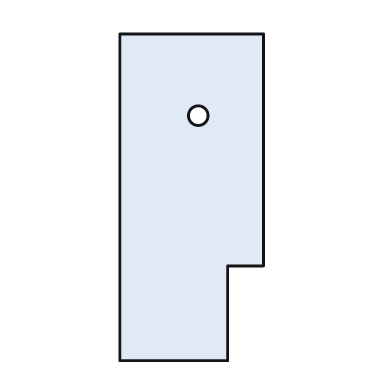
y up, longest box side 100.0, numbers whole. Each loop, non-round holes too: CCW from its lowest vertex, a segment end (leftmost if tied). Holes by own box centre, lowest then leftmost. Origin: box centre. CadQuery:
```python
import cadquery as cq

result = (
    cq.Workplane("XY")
    .moveTo(-22.0, -50.0)
    .lineTo(11.0, -50.0)
    .lineTo(11.0, -21.0)
    .lineTo(22.0, -21.0)
    .lineTo(22.0, 50.0)
    .lineTo(-22.0, 50.0)
    .close()
    .moveTo(2.0, 25.0)
    .circle(3.0)
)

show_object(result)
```